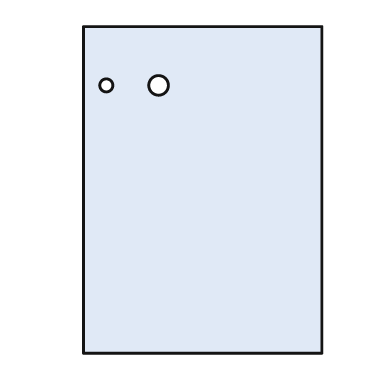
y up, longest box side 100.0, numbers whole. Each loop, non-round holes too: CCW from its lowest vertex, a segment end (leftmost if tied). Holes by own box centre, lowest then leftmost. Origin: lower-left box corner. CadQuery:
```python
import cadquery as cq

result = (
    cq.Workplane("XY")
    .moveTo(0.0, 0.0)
    .lineTo(73.0, 0.0)
    .lineTo(73.0, 100.0)
    .lineTo(0.0, 100.0)
    .close()
    .moveTo(7.0, 82.0)
    .circle(2.0)
    .moveTo(23.0, 82.0)
    .circle(3.0)
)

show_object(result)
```